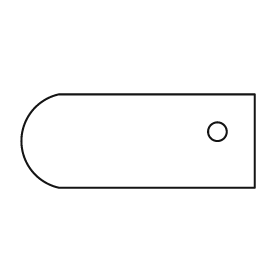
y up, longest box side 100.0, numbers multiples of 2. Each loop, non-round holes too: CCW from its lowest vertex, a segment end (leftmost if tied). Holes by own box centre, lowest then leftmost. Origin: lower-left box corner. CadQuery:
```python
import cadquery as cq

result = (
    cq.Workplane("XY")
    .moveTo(16.0, 0.0)
    .lineTo(100.0, 0.0)
    .lineTo(100.0, 40.0)
    .lineTo(16.0, 40.0)
    .threePointArc((0.0, 20.0), (16.0, 0.0))
    .close()
    .moveTo(84.0, 24.0)
    .circle(4.0)
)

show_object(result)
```